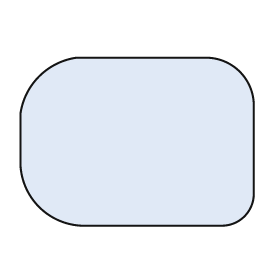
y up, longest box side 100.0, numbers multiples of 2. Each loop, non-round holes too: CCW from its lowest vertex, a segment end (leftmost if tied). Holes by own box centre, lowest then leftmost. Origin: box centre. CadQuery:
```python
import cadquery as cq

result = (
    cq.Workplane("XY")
    .moveTo(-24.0, -36.0)
    .lineTo(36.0, -36.0)
    .threePointArc((46.0, -32.0), (50.0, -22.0))
    .lineTo(50.0, 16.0)
    .threePointArc((44.0, 30.0), (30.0, 36.0))
    .lineTo(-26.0, 36.0)
    .threePointArc((-42.0, 28.0), (-50.0, 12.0))
    .lineTo(-50.0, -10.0)
    .threePointArc((-42.0, -28.0), (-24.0, -36.0))
    .close()
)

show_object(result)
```